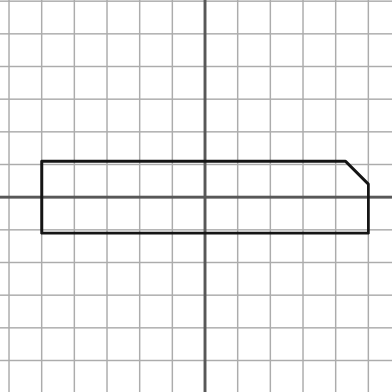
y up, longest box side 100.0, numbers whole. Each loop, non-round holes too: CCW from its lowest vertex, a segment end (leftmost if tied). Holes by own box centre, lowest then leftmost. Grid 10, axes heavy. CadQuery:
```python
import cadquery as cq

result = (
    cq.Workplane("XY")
    .moveTo(-50.0, -11.0)
    .lineTo(50.0, -11.0)
    .lineTo(50.0, 4.0)
    .lineTo(43.0, 11.0)
    .lineTo(-50.0, 11.0)
    .close()
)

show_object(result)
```